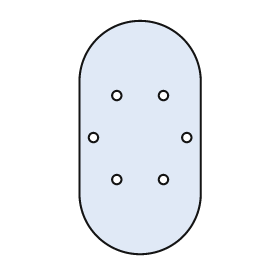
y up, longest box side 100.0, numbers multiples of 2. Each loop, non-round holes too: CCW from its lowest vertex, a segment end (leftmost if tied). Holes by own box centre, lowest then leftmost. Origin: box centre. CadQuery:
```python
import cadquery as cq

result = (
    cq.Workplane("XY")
    .moveTo(-26.0, -24.0)
    .threePointArc((0.0, -50.0), (26.0, -24.0))
    .lineTo(26.0, 24.0)
    .threePointArc((0.0, 50.0), (-26.0, 24.0))
    .close()
    .moveTo(-10.0, -18.0)
    .circle(2.0)
    .moveTo(10.0, -18.0)
    .circle(2.0)
    .moveTo(-20.0, 0.0)
    .circle(2.0)
    .moveTo(20.0, 0.0)
    .circle(2.0)
    .moveTo(-10.0, 18.0)
    .circle(2.0)
    .moveTo(10.0, 18.0)
    .circle(2.0)
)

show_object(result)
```